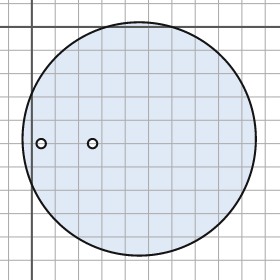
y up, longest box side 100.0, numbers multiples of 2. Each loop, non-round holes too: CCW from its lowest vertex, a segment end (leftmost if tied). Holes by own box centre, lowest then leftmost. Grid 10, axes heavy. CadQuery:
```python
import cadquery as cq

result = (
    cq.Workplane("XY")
    .moveTo(46.0, -48.0)
    .circle(50.0)
    .moveTo(4.0, -50.0)
    .circle(2.0)
    .moveTo(26.0, -50.0)
    .circle(2.0)
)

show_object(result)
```